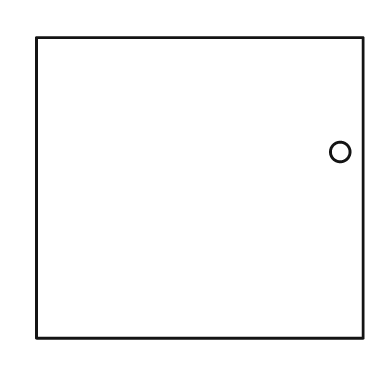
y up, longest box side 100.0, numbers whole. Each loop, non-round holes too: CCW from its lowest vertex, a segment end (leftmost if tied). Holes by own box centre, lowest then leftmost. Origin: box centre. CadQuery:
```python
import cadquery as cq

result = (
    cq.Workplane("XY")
    .moveTo(-50.0, -46.0)
    .lineTo(50.0, -46.0)
    .lineTo(50.0, 46.0)
    .lineTo(-50.0, 46.0)
    .close()
    .moveTo(43.0, 11.0)
    .circle(3.0)
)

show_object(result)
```